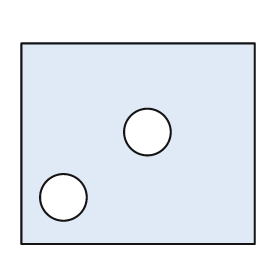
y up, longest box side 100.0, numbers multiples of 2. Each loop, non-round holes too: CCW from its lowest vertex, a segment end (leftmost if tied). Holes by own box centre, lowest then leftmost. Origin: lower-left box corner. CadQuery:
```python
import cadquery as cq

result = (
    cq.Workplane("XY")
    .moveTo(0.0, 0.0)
    .lineTo(100.0, 0.0)
    .lineTo(100.0, 86.0)
    .lineTo(0.0, 86.0)
    .close()
    .moveTo(18.0, 20.0)
    .circle(10.0)
    .moveTo(54.0, 48.0)
    .circle(10.0)
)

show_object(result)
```